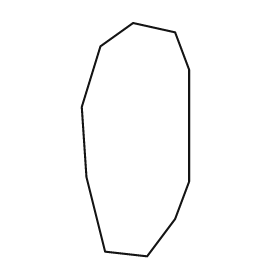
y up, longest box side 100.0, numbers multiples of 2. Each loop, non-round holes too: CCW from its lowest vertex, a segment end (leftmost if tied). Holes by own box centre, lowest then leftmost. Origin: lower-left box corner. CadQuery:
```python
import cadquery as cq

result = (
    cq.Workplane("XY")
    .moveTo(28.0, 0.0)
    .lineTo(40.0, 16.0)
    .lineTo(46.0, 32.0)
    .lineTo(46.0, 80.0)
    .lineTo(40.0, 96.0)
    .lineTo(22.0, 100.0)
    .lineTo(8.0, 90.0)
    .lineTo(0.0, 64.0)
    .lineTo(2.0, 34.0)
    .lineTo(10.0, 2.0)
    .close()
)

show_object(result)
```